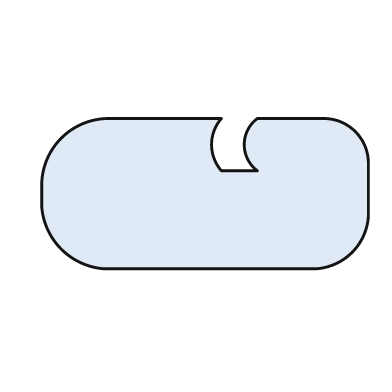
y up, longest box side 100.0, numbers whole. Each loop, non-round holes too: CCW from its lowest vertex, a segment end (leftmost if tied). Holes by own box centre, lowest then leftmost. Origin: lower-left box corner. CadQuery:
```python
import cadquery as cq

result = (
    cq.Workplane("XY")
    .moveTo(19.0, 0.0)
    .lineTo(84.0, 0.0)
    .threePointArc((95.0, 5.0), (100.0, 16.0))
    .lineTo(100.0, 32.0)
    .threePointArc((96.0, 42.0), (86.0, 46.0))
    .lineTo(66.0, 46.0)
    .threePointArc((62.0, 38.0), (66.0, 30.0))
    .lineTo(55.0, 30.0)
    .threePointArc((52.0, 38.0), (55.0, 46.0))
    .lineTo(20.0, 46.0)
    .threePointArc((6.0, 40.0), (0.0, 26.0))
    .lineTo(0.0, 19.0)
    .threePointArc((6.0, 6.0), (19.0, 0.0))
    .close()
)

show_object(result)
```